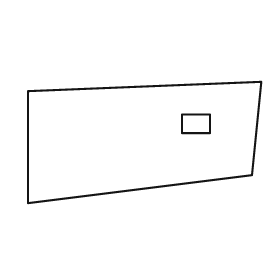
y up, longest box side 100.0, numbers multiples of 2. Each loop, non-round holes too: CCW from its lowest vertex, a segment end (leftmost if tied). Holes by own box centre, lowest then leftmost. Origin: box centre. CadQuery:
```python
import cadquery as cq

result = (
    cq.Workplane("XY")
    .moveTo(-50.0, -26.0)
    .lineTo(46.0, -14.0)
    .lineTo(50.0, 26.0)
    .lineTo(-50.0, 22.0)
    .close()
    .moveTo(16.0, 4.0)
    .lineTo(28.0, 4.0)
    .lineTo(28.0, 12.0)
    .lineTo(16.0, 12.0)
    .close()
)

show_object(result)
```